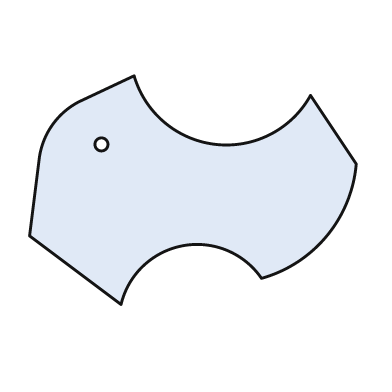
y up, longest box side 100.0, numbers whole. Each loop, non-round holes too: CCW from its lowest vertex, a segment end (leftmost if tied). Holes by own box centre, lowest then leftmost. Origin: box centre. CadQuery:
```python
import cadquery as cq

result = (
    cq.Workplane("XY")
    .moveTo(-22.0, -35.0)
    .threePointArc((-3.0, -17.0), (21.0, -27.0))
    .threePointArc((41.0, -14.0), (50.0, 8.0))
    .lineTo(36.0, 29.0)
    .threePointArc((7.0, 14.0), (-18.0, 35.0))
    .lineTo(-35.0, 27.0)
    .threePointArc((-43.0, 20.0), (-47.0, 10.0))
    .lineTo(-50.0, -14.0)
    .close()
    .moveTo(-28.0, 14.0)
    .circle(2.0)
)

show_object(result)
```